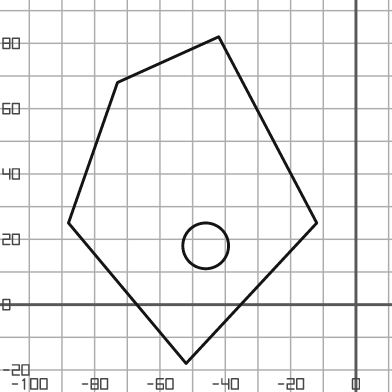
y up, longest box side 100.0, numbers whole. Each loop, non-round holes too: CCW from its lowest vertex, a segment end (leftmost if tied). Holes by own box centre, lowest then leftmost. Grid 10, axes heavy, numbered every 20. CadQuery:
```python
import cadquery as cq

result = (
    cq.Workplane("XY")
    .moveTo(-52.0, -18.0)
    .lineTo(-12.0, 25.0)
    .lineTo(-42.0, 82.0)
    .lineTo(-73.0, 68.0)
    .lineTo(-88.0, 25.0)
    .close()
    .moveTo(-46.0, 18.0)
    .circle(7.0)
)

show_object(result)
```